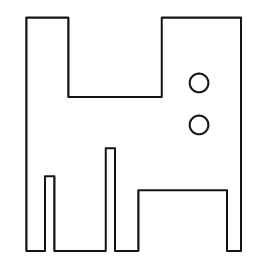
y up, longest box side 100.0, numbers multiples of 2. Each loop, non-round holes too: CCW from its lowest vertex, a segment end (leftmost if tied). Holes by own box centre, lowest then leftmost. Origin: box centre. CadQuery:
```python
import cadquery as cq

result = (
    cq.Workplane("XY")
    .moveTo(-46.0, -50.0)
    .lineTo(-38.0, -50.0)
    .lineTo(-38.0, -18.0)
    .lineTo(-34.0, -18.0)
    .lineTo(-34.0, -50.0)
    .lineTo(-12.0, -50.0)
    .lineTo(-12.0, -6.0)
    .lineTo(-8.0, -6.0)
    .lineTo(-8.0, -50.0)
    .lineTo(2.0, -50.0)
    .lineTo(2.0, -24.0)
    .lineTo(40.0, -24.0)
    .lineTo(40.0, -50.0)
    .lineTo(46.0, -50.0)
    .lineTo(46.0, 50.0)
    .lineTo(12.0, 50.0)
    .lineTo(12.0, 16.0)
    .lineTo(-28.0, 16.0)
    .lineTo(-28.0, 50.0)
    .lineTo(-46.0, 50.0)
    .close()
    .moveTo(28.0, 4.0)
    .circle(4.0)
    .moveTo(28.0, 22.0)
    .circle(4.0)
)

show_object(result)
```